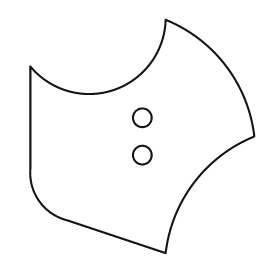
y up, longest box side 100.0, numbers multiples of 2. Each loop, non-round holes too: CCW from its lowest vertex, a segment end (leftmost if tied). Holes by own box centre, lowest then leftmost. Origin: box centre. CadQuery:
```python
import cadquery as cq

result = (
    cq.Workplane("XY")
    .moveTo(10.0, -50.0)
    .threePointArc((22.0, -20.0), (48.0, 0.0))
    .threePointArc((36.0, 30.0), (10.0, 50.0))
    .threePointArc((-12.0, 20.0), (-48.0, 30.0))
    .lineTo(-48.0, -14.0)
    .threePointArc((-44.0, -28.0), (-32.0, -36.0))
    .close()
    .moveTo(0.0, -8.0)
    .circle(4.0)
    .moveTo(0.0, 8.0)
    .circle(4.0)
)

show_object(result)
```